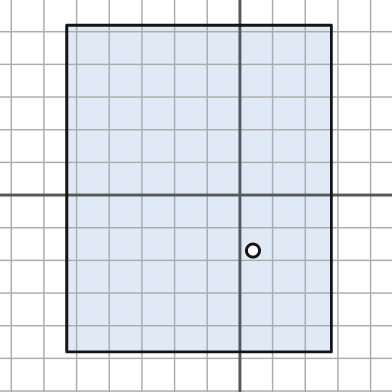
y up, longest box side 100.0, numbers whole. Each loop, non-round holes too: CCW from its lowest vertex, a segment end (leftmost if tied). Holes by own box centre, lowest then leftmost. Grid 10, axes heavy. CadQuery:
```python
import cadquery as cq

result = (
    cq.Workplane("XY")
    .moveTo(-53.0, -48.0)
    .lineTo(28.0, -48.0)
    .lineTo(28.0, 52.0)
    .lineTo(-53.0, 52.0)
    .close()
    .moveTo(4.0, -17.0)
    .circle(2.0)
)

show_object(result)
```